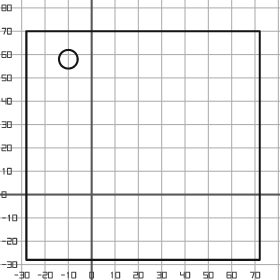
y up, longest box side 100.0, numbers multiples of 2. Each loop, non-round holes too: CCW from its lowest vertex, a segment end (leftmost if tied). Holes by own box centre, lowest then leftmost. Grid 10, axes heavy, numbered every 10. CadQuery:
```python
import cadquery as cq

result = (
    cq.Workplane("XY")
    .moveTo(-28.0, -28.0)
    .lineTo(72.0, -28.0)
    .lineTo(72.0, 70.0)
    .lineTo(-28.0, 70.0)
    .close()
    .moveTo(-10.0, 58.0)
    .circle(4.0)
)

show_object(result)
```